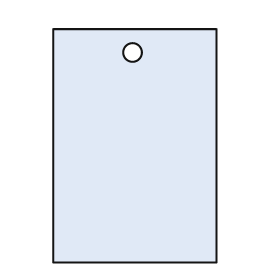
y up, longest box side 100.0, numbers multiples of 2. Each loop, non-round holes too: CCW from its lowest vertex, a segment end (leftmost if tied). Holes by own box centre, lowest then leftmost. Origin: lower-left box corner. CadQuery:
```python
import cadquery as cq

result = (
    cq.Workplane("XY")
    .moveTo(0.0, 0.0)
    .lineTo(70.0, 0.0)
    .lineTo(70.0, 100.0)
    .lineTo(0.0, 100.0)
    .close()
    .moveTo(34.0, 90.0)
    .circle(4.0)
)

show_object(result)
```